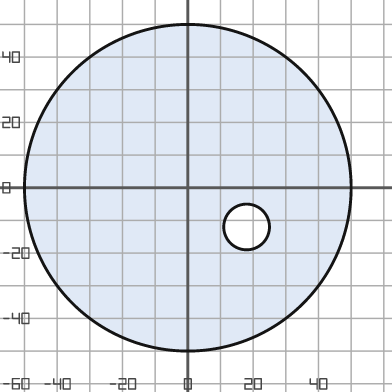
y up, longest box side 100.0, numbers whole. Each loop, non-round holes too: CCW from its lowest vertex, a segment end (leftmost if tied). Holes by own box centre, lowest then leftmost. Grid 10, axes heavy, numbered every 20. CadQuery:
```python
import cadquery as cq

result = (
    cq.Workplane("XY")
    .moveTo(0.0, 0.0)
    .circle(50.0)
    .moveTo(18.0, -12.0)
    .circle(7.0)
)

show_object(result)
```